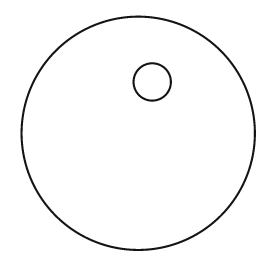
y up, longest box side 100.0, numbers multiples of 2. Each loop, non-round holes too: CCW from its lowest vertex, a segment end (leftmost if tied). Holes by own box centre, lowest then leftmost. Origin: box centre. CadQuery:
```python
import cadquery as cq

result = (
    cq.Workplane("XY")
    .moveTo(0.0, 0.0)
    .circle(50.0)
    .moveTo(6.0, 22.0)
    .circle(8.0)
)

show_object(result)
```